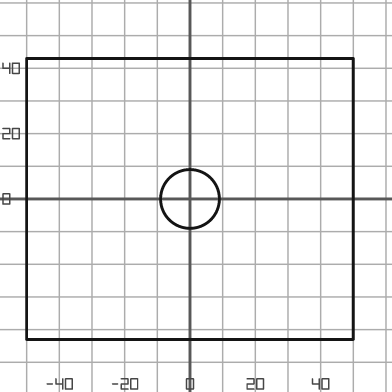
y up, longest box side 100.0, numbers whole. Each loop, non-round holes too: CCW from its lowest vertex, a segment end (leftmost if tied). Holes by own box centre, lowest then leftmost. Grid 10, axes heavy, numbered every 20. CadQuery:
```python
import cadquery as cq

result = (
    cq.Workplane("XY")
    .moveTo(-50.0, -43.0)
    .lineTo(50.0, -43.0)
    .lineTo(50.0, 43.0)
    .lineTo(-50.0, 43.0)
    .close()
    .moveTo(0.0, 0.0)
    .circle(9.0)
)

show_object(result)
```